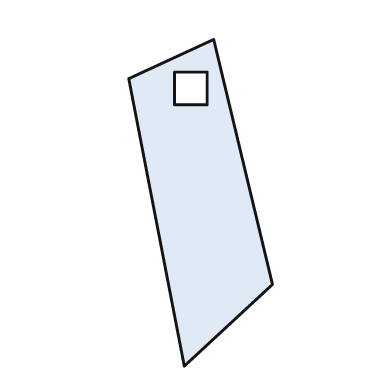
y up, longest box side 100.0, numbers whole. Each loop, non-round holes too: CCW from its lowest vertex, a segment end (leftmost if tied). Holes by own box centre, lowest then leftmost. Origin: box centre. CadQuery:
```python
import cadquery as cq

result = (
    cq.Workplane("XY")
    .moveTo(-5.0, -50.0)
    .lineTo(22.0, -25.0)
    .lineTo(4.0, 50.0)
    .lineTo(-22.0, 38.0)
    .close()
    .moveTo(-8.0, 30.0)
    .lineTo(2.0, 30.0)
    .lineTo(2.0, 40.0)
    .lineTo(-8.0, 40.0)
    .close()
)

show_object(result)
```